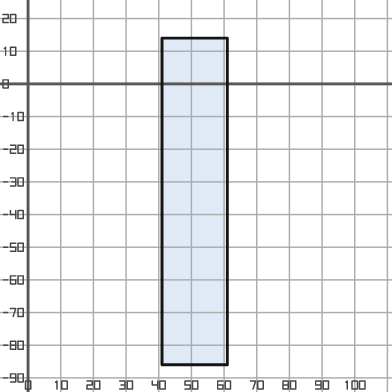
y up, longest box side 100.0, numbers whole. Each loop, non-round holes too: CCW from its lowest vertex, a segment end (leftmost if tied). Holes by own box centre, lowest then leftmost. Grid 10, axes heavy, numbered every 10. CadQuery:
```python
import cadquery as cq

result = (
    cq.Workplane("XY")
    .moveTo(41.0, -86.0)
    .lineTo(61.0, -86.0)
    .lineTo(61.0, 14.0)
    .lineTo(41.0, 14.0)
    .close()
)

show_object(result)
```